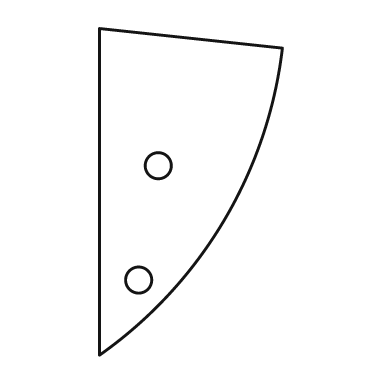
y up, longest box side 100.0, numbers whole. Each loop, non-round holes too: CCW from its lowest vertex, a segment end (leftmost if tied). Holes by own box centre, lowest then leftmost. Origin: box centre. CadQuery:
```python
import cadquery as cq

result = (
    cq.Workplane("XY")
    .moveTo(-28.0, -50.0)
    .threePointArc((10.0, -9.0), (28.0, 44.0))
    .lineTo(-28.0, 50.0)
    .close()
    .moveTo(-16.0, -27.0)
    .circle(4.0)
    .moveTo(-10.0, 8.0)
    .circle(4.0)
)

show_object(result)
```